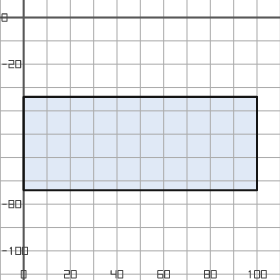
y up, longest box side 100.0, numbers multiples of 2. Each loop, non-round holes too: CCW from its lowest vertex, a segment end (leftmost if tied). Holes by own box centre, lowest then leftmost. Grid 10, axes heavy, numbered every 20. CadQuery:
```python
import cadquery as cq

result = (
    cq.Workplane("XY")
    .moveTo(0.0, -74.0)
    .lineTo(100.0, -74.0)
    .lineTo(100.0, -34.0)
    .lineTo(0.0, -34.0)
    .close()
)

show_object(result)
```